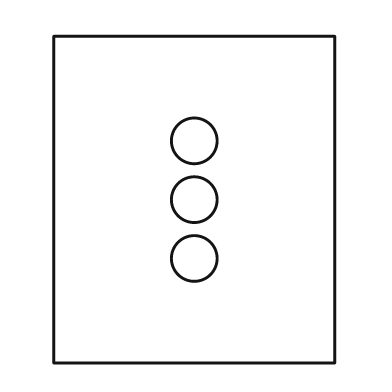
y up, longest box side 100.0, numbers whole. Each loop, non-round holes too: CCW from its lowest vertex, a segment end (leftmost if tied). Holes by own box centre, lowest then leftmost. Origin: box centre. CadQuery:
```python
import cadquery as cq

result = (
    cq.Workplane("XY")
    .moveTo(-43.0, -50.0)
    .lineTo(43.0, -50.0)
    .lineTo(43.0, 50.0)
    .lineTo(-43.0, 50.0)
    .close()
    .moveTo(0.0, -18.0)
    .circle(7.0)
    .moveTo(0.0, 0.0)
    .circle(7.0)
    .moveTo(0.0, 18.0)
    .circle(7.0)
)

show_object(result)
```